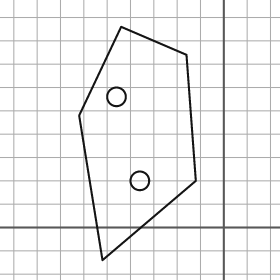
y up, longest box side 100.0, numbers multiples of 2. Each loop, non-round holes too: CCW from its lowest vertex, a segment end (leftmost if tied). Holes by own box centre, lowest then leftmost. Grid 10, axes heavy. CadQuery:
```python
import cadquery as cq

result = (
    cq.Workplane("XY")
    .moveTo(-52.0, -14.0)
    .lineTo(-12.0, 20.0)
    .lineTo(-16.0, 74.0)
    .lineTo(-44.0, 86.0)
    .lineTo(-62.0, 48.0)
    .close()
    .moveTo(-36.0, 20.0)
    .circle(4.0)
    .moveTo(-46.0, 56.0)
    .circle(4.0)
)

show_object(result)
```